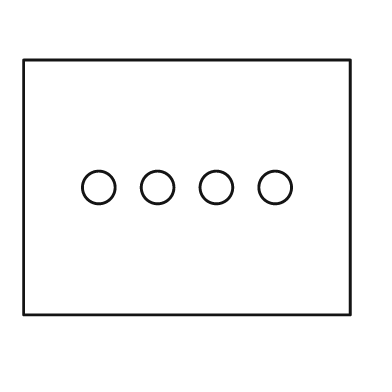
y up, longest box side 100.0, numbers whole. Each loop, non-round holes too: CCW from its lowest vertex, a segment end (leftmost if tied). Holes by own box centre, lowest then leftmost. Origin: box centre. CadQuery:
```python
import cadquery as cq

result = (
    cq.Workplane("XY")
    .moveTo(-50.0, -39.0)
    .lineTo(50.0, -39.0)
    .lineTo(50.0, 39.0)
    .lineTo(-50.0, 39.0)
    .close()
    .moveTo(-27.0, 0.0)
    .circle(5.0)
    .moveTo(-9.0, 0.0)
    .circle(5.0)
    .moveTo(9.0, 0.0)
    .circle(5.0)
    .moveTo(27.0, 0.0)
    .circle(5.0)
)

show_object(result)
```